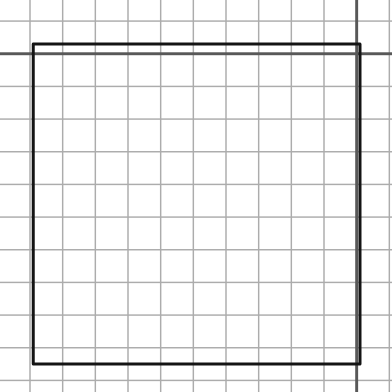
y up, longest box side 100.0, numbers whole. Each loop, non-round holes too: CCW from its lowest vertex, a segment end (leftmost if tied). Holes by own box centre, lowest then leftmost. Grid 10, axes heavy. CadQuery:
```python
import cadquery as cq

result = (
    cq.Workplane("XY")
    .moveTo(-99.0, -95.0)
    .lineTo(1.0, -95.0)
    .lineTo(1.0, 3.0)
    .lineTo(-99.0, 3.0)
    .close()
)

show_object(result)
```